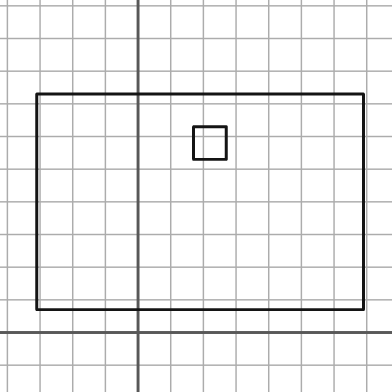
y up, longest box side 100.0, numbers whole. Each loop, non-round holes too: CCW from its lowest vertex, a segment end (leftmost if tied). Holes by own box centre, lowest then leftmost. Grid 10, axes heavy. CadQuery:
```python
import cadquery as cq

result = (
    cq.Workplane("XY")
    .moveTo(-31.0, 7.0)
    .lineTo(69.0, 7.0)
    .lineTo(69.0, 73.0)
    .lineTo(-31.0, 73.0)
    .close()
    .moveTo(17.0, 53.0)
    .lineTo(27.0, 53.0)
    .lineTo(27.0, 63.0)
    .lineTo(17.0, 63.0)
    .close()
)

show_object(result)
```